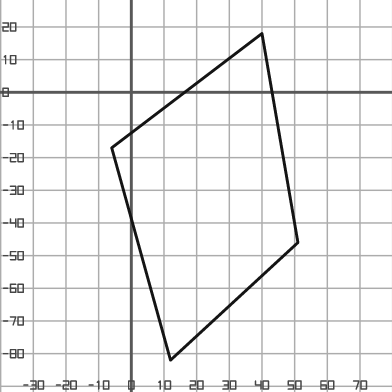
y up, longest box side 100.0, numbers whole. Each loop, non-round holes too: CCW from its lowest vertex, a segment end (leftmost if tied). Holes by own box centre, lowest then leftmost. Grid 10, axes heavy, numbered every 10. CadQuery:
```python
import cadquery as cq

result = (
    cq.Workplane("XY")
    .moveTo(12.0, -82.0)
    .lineTo(51.0, -46.0)
    .lineTo(40.0, 18.0)
    .lineTo(-6.0, -17.0)
    .close()
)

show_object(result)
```